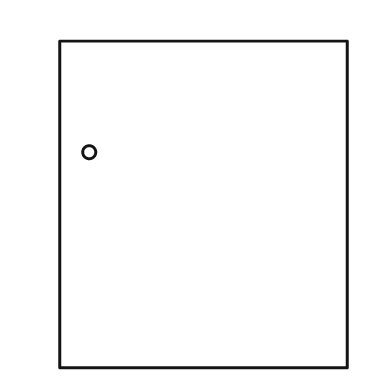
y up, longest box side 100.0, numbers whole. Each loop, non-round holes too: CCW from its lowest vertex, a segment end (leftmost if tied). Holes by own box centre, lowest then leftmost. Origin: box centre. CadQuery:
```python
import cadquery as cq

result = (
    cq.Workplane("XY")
    .moveTo(-44.0, -50.0)
    .lineTo(44.0, -50.0)
    .lineTo(44.0, 50.0)
    .lineTo(-44.0, 50.0)
    .close()
    .moveTo(-35.0, 16.0)
    .circle(2.0)
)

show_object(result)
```